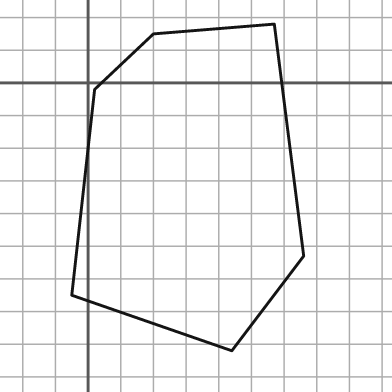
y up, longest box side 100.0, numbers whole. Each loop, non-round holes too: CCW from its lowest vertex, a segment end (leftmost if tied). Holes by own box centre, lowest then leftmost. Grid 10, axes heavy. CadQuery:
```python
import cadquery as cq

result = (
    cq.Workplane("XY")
    .moveTo(44.0, -82.0)
    .lineTo(66.0, -53.0)
    .lineTo(57.0, 18.0)
    .lineTo(20.0, 15.0)
    .lineTo(2.0, -2.0)
    .lineTo(-5.0, -65.0)
    .close()
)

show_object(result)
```